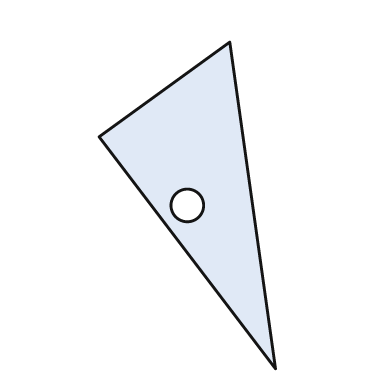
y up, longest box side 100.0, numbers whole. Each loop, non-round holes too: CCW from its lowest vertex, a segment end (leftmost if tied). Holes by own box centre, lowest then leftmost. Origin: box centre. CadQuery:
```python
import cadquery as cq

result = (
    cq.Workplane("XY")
    .moveTo(27.0, -50.0)
    .lineTo(13.0, 50.0)
    .lineTo(-27.0, 21.0)
    .close()
    .moveTo(0.0, 0.0)
    .circle(5.0)
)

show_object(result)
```